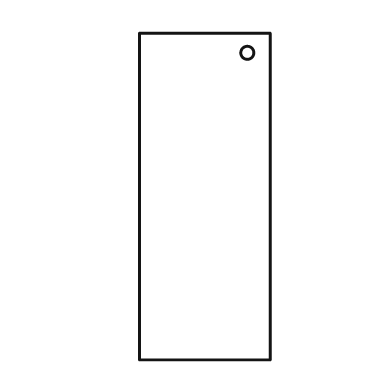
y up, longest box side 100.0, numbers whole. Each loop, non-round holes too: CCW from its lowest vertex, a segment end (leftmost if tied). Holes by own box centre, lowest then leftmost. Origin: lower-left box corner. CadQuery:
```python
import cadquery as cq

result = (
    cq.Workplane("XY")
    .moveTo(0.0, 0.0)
    .lineTo(40.0, 0.0)
    .lineTo(40.0, 100.0)
    .lineTo(0.0, 100.0)
    .close()
    .moveTo(33.0, 94.0)
    .circle(2.0)
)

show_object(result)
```